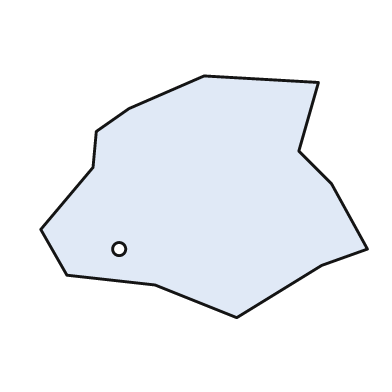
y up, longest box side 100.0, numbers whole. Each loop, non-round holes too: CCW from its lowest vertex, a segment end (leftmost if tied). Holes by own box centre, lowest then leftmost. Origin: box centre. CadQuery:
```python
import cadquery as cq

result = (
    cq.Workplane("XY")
    .moveTo(10.0, -37.0)
    .lineTo(36.0, -21.0)
    .lineTo(50.0, -16.0)
    .lineTo(39.0, 4.0)
    .lineTo(29.0, 14.0)
    .lineTo(35.0, 35.0)
    .lineTo(0.0, 37.0)
    .lineTo(-23.0, 27.0)
    .lineTo(-33.0, 20.0)
    .lineTo(-34.0, 9.0)
    .lineTo(-50.0, -10.0)
    .lineTo(-42.0, -24.0)
    .lineTo(-15.0, -27.0)
    .close()
    .moveTo(-26.0, -16.0)
    .circle(2.0)
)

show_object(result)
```